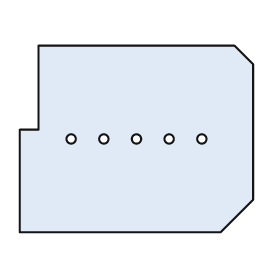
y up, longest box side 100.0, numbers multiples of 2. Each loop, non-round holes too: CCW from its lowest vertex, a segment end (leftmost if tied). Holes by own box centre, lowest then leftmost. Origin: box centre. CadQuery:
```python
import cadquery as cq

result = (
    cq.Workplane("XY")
    .moveTo(-50.0, -40.0)
    .lineTo(36.0, -40.0)
    .lineTo(50.0, -26.0)
    .lineTo(50.0, 32.0)
    .lineTo(42.0, 40.0)
    .lineTo(-42.0, 40.0)
    .lineTo(-42.0, 4.0)
    .lineTo(-50.0, 4.0)
    .close()
    .moveTo(-28.0, 0.0)
    .circle(2.0)
    .moveTo(-14.0, 0.0)
    .circle(2.0)
    .moveTo(0.0, 0.0)
    .circle(2.0)
    .moveTo(14.0, 0.0)
    .circle(2.0)
    .moveTo(28.0, 0.0)
    .circle(2.0)
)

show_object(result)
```